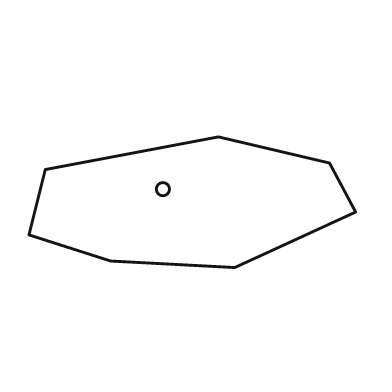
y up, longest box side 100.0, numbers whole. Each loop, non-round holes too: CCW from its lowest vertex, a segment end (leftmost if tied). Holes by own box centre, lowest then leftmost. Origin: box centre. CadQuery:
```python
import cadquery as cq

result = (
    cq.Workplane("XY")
    .moveTo(13.0, -20.0)
    .lineTo(50.0, -3.0)
    .lineTo(42.0, 12.0)
    .lineTo(8.0, 20.0)
    .lineTo(-45.0, 10.0)
    .lineTo(-50.0, -10.0)
    .lineTo(-25.0, -18.0)
    .close()
    .moveTo(-9.0, 4.0)
    .circle(2.0)
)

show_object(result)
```